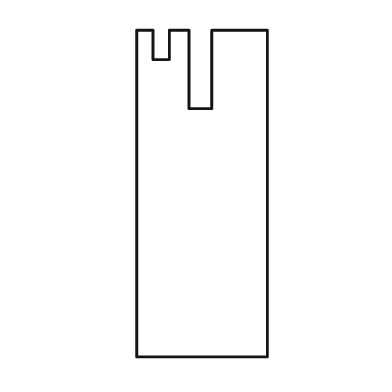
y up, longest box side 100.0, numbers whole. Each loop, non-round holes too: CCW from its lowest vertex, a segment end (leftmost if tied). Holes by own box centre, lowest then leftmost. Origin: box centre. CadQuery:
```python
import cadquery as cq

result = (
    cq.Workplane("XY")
    .moveTo(-20.0, -50.0)
    .lineTo(20.0, -50.0)
    .lineTo(20.0, 50.0)
    .lineTo(3.0, 50.0)
    .lineTo(3.0, 26.0)
    .lineTo(-4.0, 26.0)
    .lineTo(-4.0, 50.0)
    .lineTo(-10.0, 50.0)
    .lineTo(-10.0, 41.0)
    .lineTo(-15.0, 41.0)
    .lineTo(-15.0, 50.0)
    .lineTo(-20.0, 50.0)
    .close()
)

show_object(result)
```